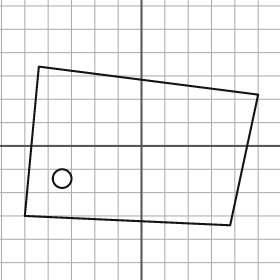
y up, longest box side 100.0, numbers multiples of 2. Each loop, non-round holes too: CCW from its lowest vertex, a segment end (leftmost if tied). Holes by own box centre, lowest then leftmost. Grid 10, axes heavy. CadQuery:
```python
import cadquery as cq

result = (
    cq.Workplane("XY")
    .moveTo(38.0, -34.0)
    .lineTo(50.0, 22.0)
    .lineTo(-44.0, 34.0)
    .lineTo(-50.0, -30.0)
    .close()
    .moveTo(-34.0, -14.0)
    .circle(4.0)
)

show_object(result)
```